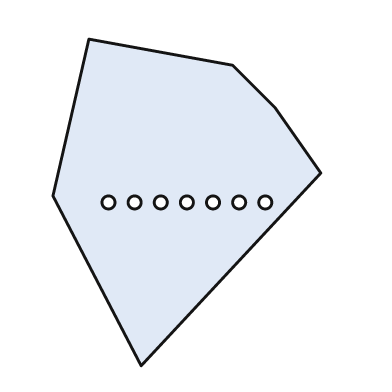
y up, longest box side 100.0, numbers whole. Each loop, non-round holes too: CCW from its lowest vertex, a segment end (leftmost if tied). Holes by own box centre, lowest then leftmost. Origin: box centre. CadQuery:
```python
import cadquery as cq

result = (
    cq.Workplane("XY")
    .moveTo(-14.0, -50.0)
    .lineTo(41.0, 9.0)
    .lineTo(27.0, 29.0)
    .lineTo(14.0, 42.0)
    .lineTo(-30.0, 50.0)
    .lineTo(-41.0, 2.0)
    .close()
    .moveTo(-24.0, 0.0)
    .circle(2.0)
    .moveTo(-16.0, 0.0)
    .circle(2.0)
    .moveTo(-8.0, 0.0)
    .circle(2.0)
    .moveTo(0.0, 0.0)
    .circle(2.0)
    .moveTo(8.0, 0.0)
    .circle(2.0)
    .moveTo(16.0, 0.0)
    .circle(2.0)
    .moveTo(24.0, 0.0)
    .circle(2.0)
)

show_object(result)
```